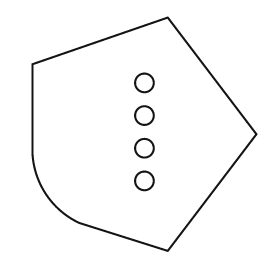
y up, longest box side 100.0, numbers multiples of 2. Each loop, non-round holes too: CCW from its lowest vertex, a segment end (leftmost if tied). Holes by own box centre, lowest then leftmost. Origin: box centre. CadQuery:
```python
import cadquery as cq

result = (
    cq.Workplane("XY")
    .moveTo(10.0, -50.0)
    .lineTo(48.0, 0.0)
    .lineTo(10.0, 50.0)
    .lineTo(-48.0, 30.0)
    .lineTo(-48.0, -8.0)
    .threePointArc((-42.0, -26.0), (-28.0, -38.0))
    .close()
    .moveTo(0.0, -20.0)
    .circle(4.0)
    .moveTo(0.0, -6.0)
    .circle(4.0)
    .moveTo(0.0, 8.0)
    .circle(4.0)
    .moveTo(0.0, 22.0)
    .circle(4.0)
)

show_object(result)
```